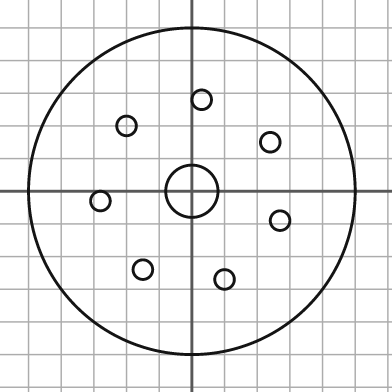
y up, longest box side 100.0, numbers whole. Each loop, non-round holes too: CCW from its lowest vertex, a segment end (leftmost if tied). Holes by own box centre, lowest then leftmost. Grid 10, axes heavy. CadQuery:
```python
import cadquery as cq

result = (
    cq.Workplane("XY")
    .moveTo(0.0, 0.0)
    .circle(50.0)
    .moveTo(10.0, -27.0)
    .circle(3.0)
    .moveTo(-15.0, -24.0)
    .circle(3.0)
    .moveTo(27.0, -9.0)
    .circle(3.0)
    .moveTo(-28.0, -3.0)
    .circle(3.0)
    .moveTo(0.0, 0.0)
    .circle(8.0)
    .moveTo(24.0, 15.0)
    .circle(3.0)
    .moveTo(-20.0, 20.0)
    .circle(3.0)
    .moveTo(3.0, 28.0)
    .circle(3.0)
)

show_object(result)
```